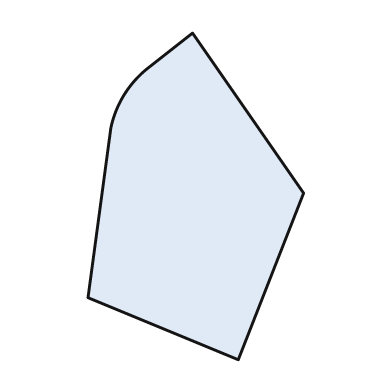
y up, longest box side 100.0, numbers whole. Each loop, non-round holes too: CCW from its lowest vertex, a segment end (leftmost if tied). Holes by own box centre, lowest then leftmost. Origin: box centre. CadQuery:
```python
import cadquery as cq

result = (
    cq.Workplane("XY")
    .moveTo(13.0, -50.0)
    .lineTo(33.0, 1.0)
    .lineTo(-1.0, 50.0)
    .lineTo(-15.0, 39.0)
    .threePointArc((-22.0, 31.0), (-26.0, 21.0))
    .lineTo(-33.0, -31.0)
    .close()
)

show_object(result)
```